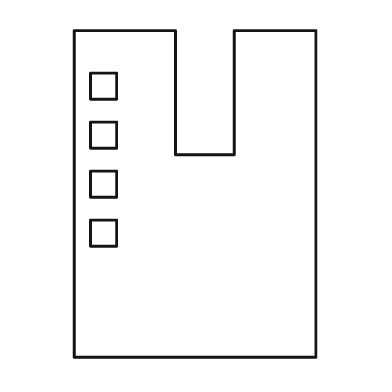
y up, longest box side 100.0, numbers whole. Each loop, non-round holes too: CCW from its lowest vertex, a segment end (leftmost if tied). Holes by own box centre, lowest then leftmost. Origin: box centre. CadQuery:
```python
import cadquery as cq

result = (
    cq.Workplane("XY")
    .moveTo(-37.0, -50.0)
    .lineTo(37.0, -50.0)
    .lineTo(37.0, 50.0)
    .lineTo(12.0, 50.0)
    .lineTo(12.0, 12.0)
    .lineTo(-6.0, 12.0)
    .lineTo(-6.0, 50.0)
    .lineTo(-37.0, 50.0)
    .close()
    .moveTo(-32.0, -16.0)
    .lineTo(-24.0, -16.0)
    .lineTo(-24.0, -8.0)
    .lineTo(-32.0, -8.0)
    .close()
    .moveTo(-32.0, -1.0)
    .lineTo(-24.0, -1.0)
    .lineTo(-24.0, 7.0)
    .lineTo(-32.0, 7.0)
    .close()
    .moveTo(-32.0, 14.0)
    .lineTo(-24.0, 14.0)
    .lineTo(-24.0, 22.0)
    .lineTo(-32.0, 22.0)
    .close()
    .moveTo(-32.0, 29.0)
    .lineTo(-24.0, 29.0)
    .lineTo(-24.0, 37.0)
    .lineTo(-32.0, 37.0)
    .close()
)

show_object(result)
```